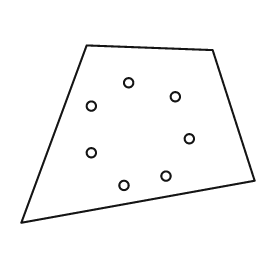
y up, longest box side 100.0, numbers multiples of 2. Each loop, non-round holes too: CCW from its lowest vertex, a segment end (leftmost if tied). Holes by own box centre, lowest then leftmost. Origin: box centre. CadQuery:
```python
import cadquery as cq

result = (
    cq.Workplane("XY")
    .moveTo(-50.0, -38.0)
    .lineTo(50.0, -20.0)
    .lineTo(32.0, 36.0)
    .lineTo(-22.0, 38.0)
    .close()
    .moveTo(-6.0, -22.0)
    .circle(2.0)
    .moveTo(12.0, -18.0)
    .circle(2.0)
    .moveTo(-20.0, -8.0)
    .circle(2.0)
    .moveTo(22.0, -2.0)
    .circle(2.0)
    .moveTo(-20.0, 12.0)
    .circle(2.0)
    .moveTo(16.0, 16.0)
    .circle(2.0)
    .moveTo(-4.0, 22.0)
    .circle(2.0)
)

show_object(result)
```